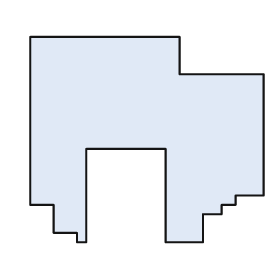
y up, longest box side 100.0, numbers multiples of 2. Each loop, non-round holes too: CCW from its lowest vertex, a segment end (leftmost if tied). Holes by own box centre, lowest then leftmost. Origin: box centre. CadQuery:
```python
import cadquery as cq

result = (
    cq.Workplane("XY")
    .moveTo(-30.0, -44.0)
    .lineTo(-26.0, -44.0)
    .lineTo(-26.0, -4.0)
    .lineTo(8.0, -4.0)
    .lineTo(8.0, -44.0)
    .lineTo(24.0, -44.0)
    .lineTo(24.0, -32.0)
    .lineTo(32.0, -32.0)
    .lineTo(32.0, -28.0)
    .lineTo(38.0, -28.0)
    .lineTo(38.0, -24.0)
    .lineTo(50.0, -24.0)
    .lineTo(50.0, 28.0)
    .lineTo(14.0, 28.0)
    .lineTo(14.0, 44.0)
    .lineTo(-50.0, 44.0)
    .lineTo(-50.0, -28.0)
    .lineTo(-40.0, -28.0)
    .lineTo(-40.0, -40.0)
    .lineTo(-30.0, -40.0)
    .close()
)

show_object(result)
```